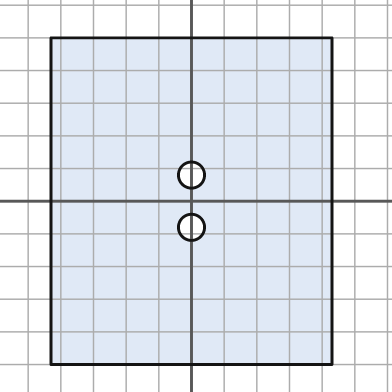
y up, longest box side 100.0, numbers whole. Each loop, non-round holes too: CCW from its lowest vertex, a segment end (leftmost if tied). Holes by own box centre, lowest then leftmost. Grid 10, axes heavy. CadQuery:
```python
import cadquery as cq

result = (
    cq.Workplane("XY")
    .moveTo(-43.0, -50.0)
    .lineTo(43.0, -50.0)
    .lineTo(43.0, 50.0)
    .lineTo(-43.0, 50.0)
    .close()
    .moveTo(0.0, -8.0)
    .circle(4.0)
    .moveTo(0.0, 8.0)
    .circle(4.0)
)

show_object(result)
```